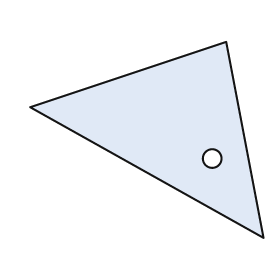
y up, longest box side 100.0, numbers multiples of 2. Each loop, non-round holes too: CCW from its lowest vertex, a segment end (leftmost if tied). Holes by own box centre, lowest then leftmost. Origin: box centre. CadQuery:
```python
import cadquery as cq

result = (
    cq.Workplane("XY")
    .moveTo(50.0, -42.0)
    .lineTo(34.0, 42.0)
    .lineTo(-50.0, 14.0)
    .close()
    .moveTo(28.0, -8.0)
    .circle(4.0)
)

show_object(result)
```